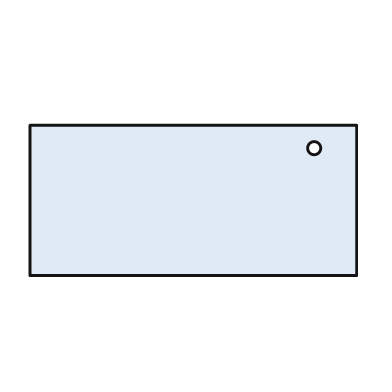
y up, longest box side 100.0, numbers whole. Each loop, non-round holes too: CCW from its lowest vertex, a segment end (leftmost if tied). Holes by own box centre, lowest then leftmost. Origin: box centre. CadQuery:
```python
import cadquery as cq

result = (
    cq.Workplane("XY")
    .moveTo(-50.0, -23.0)
    .lineTo(50.0, -23.0)
    .lineTo(50.0, 23.0)
    .lineTo(-50.0, 23.0)
    .close()
    .moveTo(37.0, 16.0)
    .circle(2.0)
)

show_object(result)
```